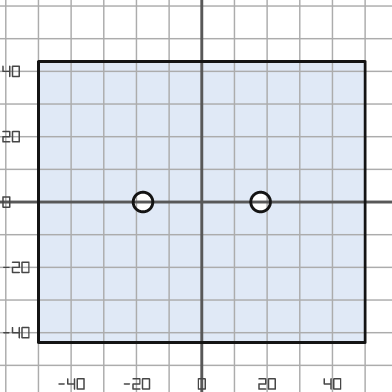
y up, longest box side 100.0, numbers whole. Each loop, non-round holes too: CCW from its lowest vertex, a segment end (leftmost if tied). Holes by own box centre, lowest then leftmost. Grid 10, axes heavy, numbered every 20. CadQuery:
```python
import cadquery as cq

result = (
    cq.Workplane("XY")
    .moveTo(-50.0, -43.0)
    .lineTo(50.0, -43.0)
    .lineTo(50.0, 43.0)
    .lineTo(-50.0, 43.0)
    .close()
    .moveTo(-18.0, 0.0)
    .circle(3.0)
    .moveTo(18.0, 0.0)
    .circle(3.0)
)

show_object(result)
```